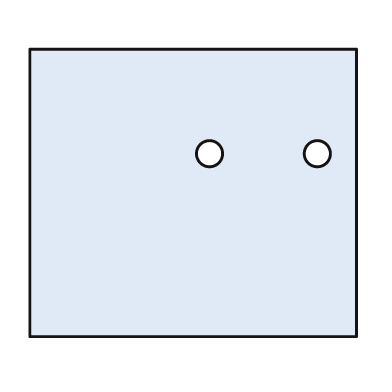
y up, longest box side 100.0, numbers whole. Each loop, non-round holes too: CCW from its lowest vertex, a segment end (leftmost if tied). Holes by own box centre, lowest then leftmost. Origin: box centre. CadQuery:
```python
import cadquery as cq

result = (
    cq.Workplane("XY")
    .moveTo(-50.0, -44.0)
    .lineTo(50.0, -44.0)
    .lineTo(50.0, 44.0)
    .lineTo(-50.0, 44.0)
    .close()
    .moveTo(5.0, 12.0)
    .circle(4.0)
    .moveTo(38.0, 12.0)
    .circle(4.0)
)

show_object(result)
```